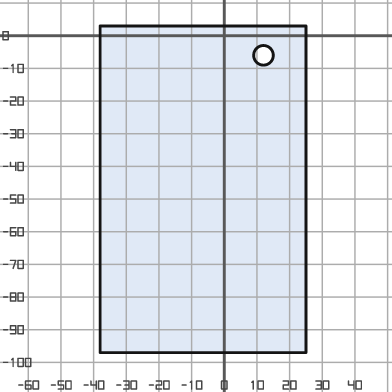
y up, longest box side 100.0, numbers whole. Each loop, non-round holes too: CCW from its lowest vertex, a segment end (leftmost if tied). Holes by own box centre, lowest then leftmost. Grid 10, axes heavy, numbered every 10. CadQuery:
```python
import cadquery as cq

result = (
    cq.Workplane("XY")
    .moveTo(-38.0, -97.0)
    .lineTo(25.0, -97.0)
    .lineTo(25.0, 3.0)
    .lineTo(-38.0, 3.0)
    .close()
    .moveTo(12.0, -6.0)
    .circle(3.0)
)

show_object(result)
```